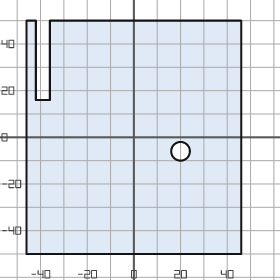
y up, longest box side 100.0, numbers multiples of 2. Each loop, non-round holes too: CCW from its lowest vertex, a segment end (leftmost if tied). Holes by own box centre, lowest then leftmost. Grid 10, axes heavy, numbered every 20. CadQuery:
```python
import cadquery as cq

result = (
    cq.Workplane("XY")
    .moveTo(-46.0, -50.0)
    .lineTo(46.0, -50.0)
    .lineTo(46.0, 50.0)
    .lineTo(-36.0, 50.0)
    .lineTo(-36.0, 16.0)
    .lineTo(-42.0, 16.0)
    .lineTo(-42.0, 50.0)
    .lineTo(-46.0, 50.0)
    .close()
    .moveTo(20.0, -6.0)
    .circle(4.0)
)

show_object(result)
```